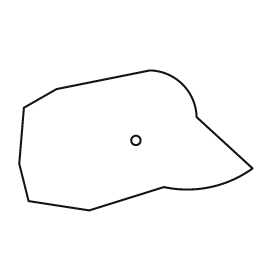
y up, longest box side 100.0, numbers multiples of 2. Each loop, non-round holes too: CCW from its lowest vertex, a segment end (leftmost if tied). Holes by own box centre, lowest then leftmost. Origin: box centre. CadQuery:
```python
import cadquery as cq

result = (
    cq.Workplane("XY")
    .moveTo(-20.0, -30.0)
    .lineTo(12.0, -20.0)
    .threePointArc((32.0, -20.0), (50.0, -12.0))
    .lineTo(26.0, 10.0)
    .threePointArc((20.0, 24.0), (6.0, 30.0))
    .lineTo(-34.0, 22.0)
    .lineTo(-48.0, 14.0)
    .lineTo(-50.0, -10.0)
    .lineTo(-46.0, -26.0)
    .close()
    .moveTo(0.0, 0.0)
    .circle(2.0)
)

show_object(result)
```